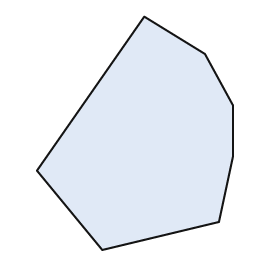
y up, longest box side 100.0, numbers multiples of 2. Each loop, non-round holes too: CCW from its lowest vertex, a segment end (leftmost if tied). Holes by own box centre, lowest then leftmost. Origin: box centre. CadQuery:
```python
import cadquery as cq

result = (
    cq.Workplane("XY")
    .moveTo(-14.0, -50.0)
    .lineTo(36.0, -38.0)
    .lineTo(42.0, -10.0)
    .lineTo(42.0, 12.0)
    .lineTo(30.0, 34.0)
    .lineTo(4.0, 50.0)
    .lineTo(-42.0, -16.0)
    .close()
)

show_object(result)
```